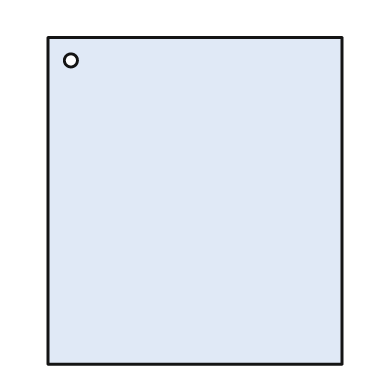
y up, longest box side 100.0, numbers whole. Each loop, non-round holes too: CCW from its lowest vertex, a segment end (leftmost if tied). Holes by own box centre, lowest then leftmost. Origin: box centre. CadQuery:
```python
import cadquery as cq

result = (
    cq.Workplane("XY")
    .moveTo(-45.0, -50.0)
    .lineTo(45.0, -50.0)
    .lineTo(45.0, 50.0)
    .lineTo(-45.0, 50.0)
    .close()
    .moveTo(-38.0, 43.0)
    .circle(2.0)
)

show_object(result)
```